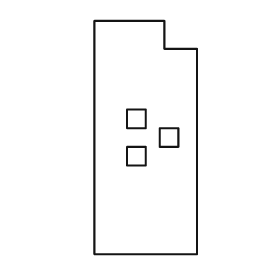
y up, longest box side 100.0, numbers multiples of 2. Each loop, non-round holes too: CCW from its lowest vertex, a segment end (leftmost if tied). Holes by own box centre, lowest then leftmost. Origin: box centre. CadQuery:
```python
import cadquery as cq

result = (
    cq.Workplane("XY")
    .moveTo(-22.0, -50.0)
    .lineTo(22.0, -50.0)
    .lineTo(22.0, 38.0)
    .lineTo(8.0, 38.0)
    .lineTo(8.0, 50.0)
    .lineTo(-22.0, 50.0)
    .close()
    .moveTo(-8.0, -12.0)
    .lineTo(0.0, -12.0)
    .lineTo(0.0, -4.0)
    .lineTo(-8.0, -4.0)
    .close()
    .moveTo(6.0, -4.0)
    .lineTo(14.0, -4.0)
    .lineTo(14.0, 4.0)
    .lineTo(6.0, 4.0)
    .close()
    .moveTo(-8.0, 4.0)
    .lineTo(0.0, 4.0)
    .lineTo(0.0, 12.0)
    .lineTo(-8.0, 12.0)
    .close()
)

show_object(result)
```